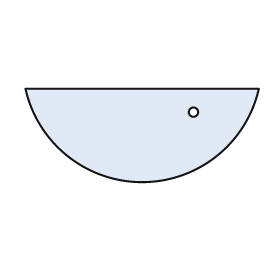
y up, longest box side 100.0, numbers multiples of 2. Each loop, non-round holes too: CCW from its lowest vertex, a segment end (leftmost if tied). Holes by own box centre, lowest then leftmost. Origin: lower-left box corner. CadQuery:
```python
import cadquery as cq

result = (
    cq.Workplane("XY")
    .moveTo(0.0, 40.0)
    .threePointArc((50.0, 0.0), (100.0, 40.0))
    .close()
    .moveTo(72.0, 30.0)
    .circle(2.0)
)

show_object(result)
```